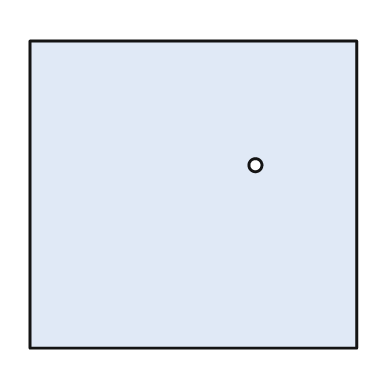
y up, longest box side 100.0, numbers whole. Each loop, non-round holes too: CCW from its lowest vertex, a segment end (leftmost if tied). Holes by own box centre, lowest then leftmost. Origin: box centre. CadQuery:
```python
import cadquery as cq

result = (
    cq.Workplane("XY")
    .moveTo(-50.0, -47.0)
    .lineTo(50.0, -47.0)
    .lineTo(50.0, 47.0)
    .lineTo(-50.0, 47.0)
    .close()
    .moveTo(19.0, 9.0)
    .circle(2.0)
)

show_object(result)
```